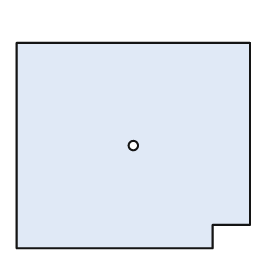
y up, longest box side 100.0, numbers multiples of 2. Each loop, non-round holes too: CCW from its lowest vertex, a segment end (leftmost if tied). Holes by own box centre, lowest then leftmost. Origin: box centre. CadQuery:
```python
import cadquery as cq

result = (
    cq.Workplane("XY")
    .moveTo(-50.0, -44.0)
    .lineTo(34.0, -44.0)
    .lineTo(34.0, -34.0)
    .lineTo(50.0, -34.0)
    .lineTo(50.0, 44.0)
    .lineTo(-50.0, 44.0)
    .close()
    .moveTo(0.0, 0.0)
    .circle(2.0)
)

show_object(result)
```